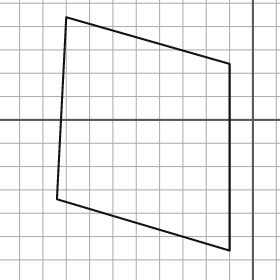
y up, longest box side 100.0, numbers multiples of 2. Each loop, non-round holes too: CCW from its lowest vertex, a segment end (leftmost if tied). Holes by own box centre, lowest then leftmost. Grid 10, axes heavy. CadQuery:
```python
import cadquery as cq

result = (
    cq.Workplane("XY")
    .moveTo(-10.0, -56.0)
    .lineTo(-10.0, 24.0)
    .lineTo(-80.0, 44.0)
    .lineTo(-84.0, -34.0)
    .close()
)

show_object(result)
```